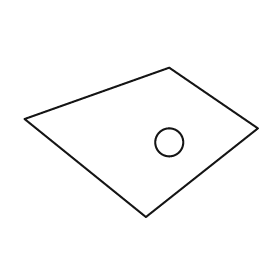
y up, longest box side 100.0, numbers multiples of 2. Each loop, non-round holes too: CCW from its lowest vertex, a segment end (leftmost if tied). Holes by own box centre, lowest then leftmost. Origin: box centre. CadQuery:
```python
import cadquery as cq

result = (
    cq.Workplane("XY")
    .moveTo(2.0, -32.0)
    .lineTo(50.0, 6.0)
    .lineTo(12.0, 32.0)
    .lineTo(-50.0, 10.0)
    .close()
    .moveTo(12.0, 0.0)
    .circle(6.0)
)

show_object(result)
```